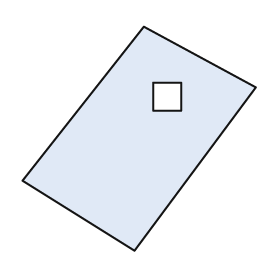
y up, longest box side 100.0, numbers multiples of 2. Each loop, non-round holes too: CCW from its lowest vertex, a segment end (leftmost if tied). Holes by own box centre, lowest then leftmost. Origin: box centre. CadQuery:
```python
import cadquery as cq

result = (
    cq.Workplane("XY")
    .moveTo(-2.0, -48.0)
    .lineTo(50.0, 22.0)
    .lineTo(2.0, 48.0)
    .lineTo(-50.0, -18.0)
    .close()
    .moveTo(6.0, 12.0)
    .lineTo(18.0, 12.0)
    .lineTo(18.0, 24.0)
    .lineTo(6.0, 24.0)
    .close()
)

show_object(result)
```